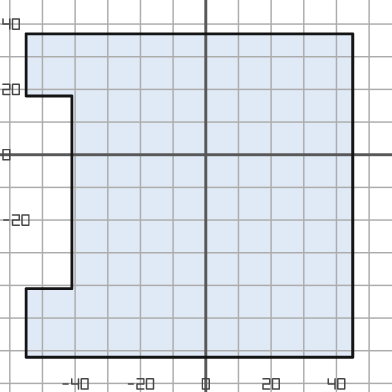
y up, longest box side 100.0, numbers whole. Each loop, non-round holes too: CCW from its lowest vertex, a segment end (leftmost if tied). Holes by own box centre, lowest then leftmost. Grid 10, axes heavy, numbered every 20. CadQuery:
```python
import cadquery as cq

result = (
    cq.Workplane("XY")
    .moveTo(-55.0, -62.0)
    .lineTo(45.0, -62.0)
    .lineTo(45.0, 37.0)
    .lineTo(-55.0, 37.0)
    .lineTo(-55.0, 18.0)
    .lineTo(-41.0, 18.0)
    .lineTo(-41.0, -41.0)
    .lineTo(-55.0, -41.0)
    .close()
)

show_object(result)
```